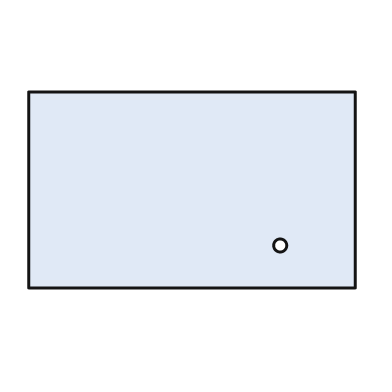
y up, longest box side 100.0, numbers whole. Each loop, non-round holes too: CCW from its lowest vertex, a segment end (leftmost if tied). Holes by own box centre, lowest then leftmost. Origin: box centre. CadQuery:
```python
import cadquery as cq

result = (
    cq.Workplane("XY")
    .moveTo(-50.0, -30.0)
    .lineTo(50.0, -30.0)
    .lineTo(50.0, 30.0)
    .lineTo(-50.0, 30.0)
    .close()
    .moveTo(27.0, -17.0)
    .circle(2.0)
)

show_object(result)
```